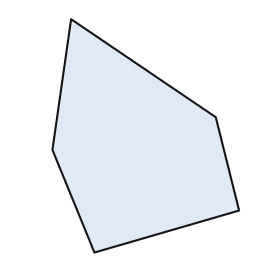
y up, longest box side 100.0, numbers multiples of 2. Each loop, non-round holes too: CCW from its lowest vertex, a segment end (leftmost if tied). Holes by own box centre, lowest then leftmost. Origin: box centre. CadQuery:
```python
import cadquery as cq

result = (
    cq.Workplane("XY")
    .moveTo(-22.0, -50.0)
    .lineTo(40.0, -32.0)
    .lineTo(30.0, 8.0)
    .lineTo(-32.0, 50.0)
    .lineTo(-40.0, -6.0)
    .close()
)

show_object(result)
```